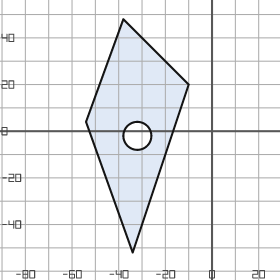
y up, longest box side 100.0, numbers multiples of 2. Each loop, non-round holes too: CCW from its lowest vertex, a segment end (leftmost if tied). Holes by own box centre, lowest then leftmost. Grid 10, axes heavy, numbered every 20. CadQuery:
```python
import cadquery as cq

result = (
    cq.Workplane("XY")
    .moveTo(-34.0, -52.0)
    .lineTo(-10.0, 20.0)
    .lineTo(-38.0, 48.0)
    .lineTo(-54.0, 4.0)
    .close()
    .moveTo(-32.0, -2.0)
    .circle(6.0)
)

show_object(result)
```